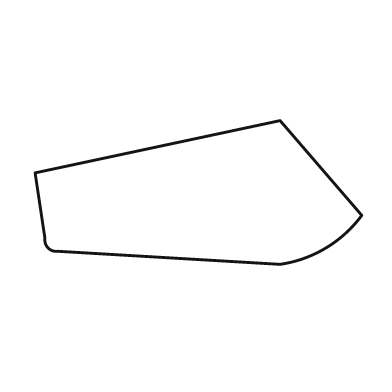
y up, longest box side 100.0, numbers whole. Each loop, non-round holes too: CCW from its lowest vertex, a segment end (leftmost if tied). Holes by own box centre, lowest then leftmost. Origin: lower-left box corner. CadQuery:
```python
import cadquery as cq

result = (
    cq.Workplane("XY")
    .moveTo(75.0, 0.0)
    .threePointArc((89.0, 5.0), (100.0, 15.0))
    .lineTo(75.0, 44.0)
    .lineTo(0.0, 28.0)
    .lineTo(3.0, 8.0)
    .threePointArc((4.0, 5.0), (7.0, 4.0))
    .close()
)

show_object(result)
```